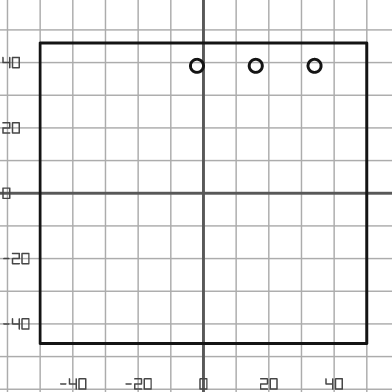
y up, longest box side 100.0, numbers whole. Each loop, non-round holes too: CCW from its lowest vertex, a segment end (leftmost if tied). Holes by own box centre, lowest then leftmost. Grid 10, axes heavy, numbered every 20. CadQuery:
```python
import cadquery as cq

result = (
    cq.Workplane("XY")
    .moveTo(-50.0, -46.0)
    .lineTo(50.0, -46.0)
    .lineTo(50.0, 46.0)
    .lineTo(-50.0, 46.0)
    .close()
    .moveTo(-2.0, 39.0)
    .circle(2.0)
    .moveTo(16.0, 39.0)
    .circle(2.0)
    .moveTo(34.0, 39.0)
    .circle(2.0)
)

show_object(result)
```